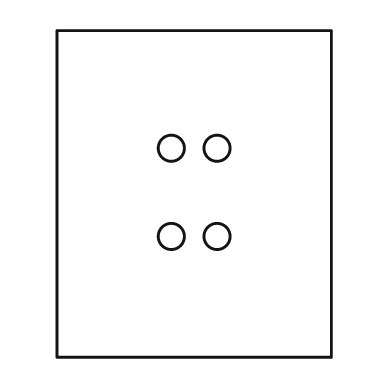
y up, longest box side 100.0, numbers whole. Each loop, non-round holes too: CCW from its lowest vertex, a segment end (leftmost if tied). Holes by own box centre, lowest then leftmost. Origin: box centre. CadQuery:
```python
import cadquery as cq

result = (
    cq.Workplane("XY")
    .moveTo(-42.0, -50.0)
    .lineTo(42.0, -50.0)
    .lineTo(42.0, 50.0)
    .lineTo(-42.0, 50.0)
    .close()
    .moveTo(-7.0, -13.0)
    .circle(4.0)
    .moveTo(7.0, -13.0)
    .circle(4.0)
    .moveTo(-7.0, 14.0)
    .circle(4.0)
    .moveTo(7.0, 14.0)
    .circle(4.0)
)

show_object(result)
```